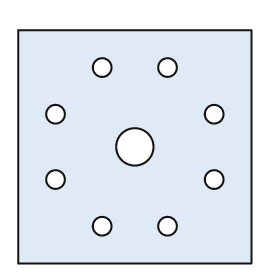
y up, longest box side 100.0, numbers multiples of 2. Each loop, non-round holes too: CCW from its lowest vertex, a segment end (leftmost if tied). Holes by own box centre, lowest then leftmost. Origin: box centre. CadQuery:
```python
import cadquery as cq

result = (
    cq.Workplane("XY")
    .moveTo(-50.0, -50.0)
    .lineTo(50.0, -50.0)
    .lineTo(50.0, 50.0)
    .lineTo(-50.0, 50.0)
    .close()
    .moveTo(-14.0, -34.0)
    .circle(4.0)
    .moveTo(14.0, -34.0)
    .circle(4.0)
    .moveTo(-34.0, -14.0)
    .circle(4.0)
    .moveTo(34.0, -14.0)
    .circle(4.0)
    .moveTo(0.0, 0.0)
    .circle(8.0)
    .moveTo(-34.0, 14.0)
    .circle(4.0)
    .moveTo(34.0, 14.0)
    .circle(4.0)
    .moveTo(-14.0, 34.0)
    .circle(4.0)
    .moveTo(14.0, 34.0)
    .circle(4.0)
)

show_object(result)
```